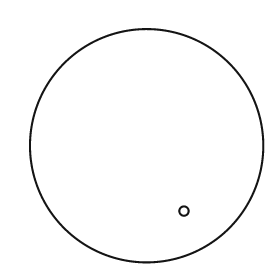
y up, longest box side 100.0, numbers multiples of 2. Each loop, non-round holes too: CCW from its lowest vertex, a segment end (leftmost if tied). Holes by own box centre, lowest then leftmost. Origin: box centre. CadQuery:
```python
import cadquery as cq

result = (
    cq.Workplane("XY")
    .moveTo(0.0, 0.0)
    .circle(50.0)
    .moveTo(16.0, -28.0)
    .circle(2.0)
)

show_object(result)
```